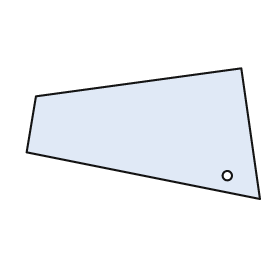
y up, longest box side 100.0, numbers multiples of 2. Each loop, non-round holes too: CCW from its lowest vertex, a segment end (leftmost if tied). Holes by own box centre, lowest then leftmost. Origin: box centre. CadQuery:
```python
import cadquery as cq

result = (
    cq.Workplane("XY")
    .moveTo(50.0, -28.0)
    .lineTo(42.0, 28.0)
    .lineTo(-46.0, 16.0)
    .lineTo(-50.0, -8.0)
    .close()
    .moveTo(36.0, -18.0)
    .circle(2.0)
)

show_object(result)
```